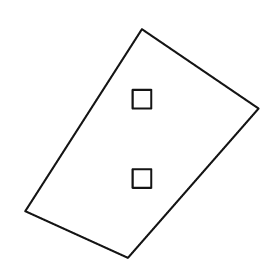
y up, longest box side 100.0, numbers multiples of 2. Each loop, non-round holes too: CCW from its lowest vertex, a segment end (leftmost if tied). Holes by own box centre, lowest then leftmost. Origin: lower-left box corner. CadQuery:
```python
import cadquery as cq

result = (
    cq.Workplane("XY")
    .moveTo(44.0, 0.0)
    .lineTo(100.0, 64.0)
    .lineTo(50.0, 98.0)
    .lineTo(0.0, 20.0)
    .close()
    .moveTo(46.0, 30.0)
    .lineTo(54.0, 30.0)
    .lineTo(54.0, 38.0)
    .lineTo(46.0, 38.0)
    .close()
    .moveTo(46.0, 64.0)
    .lineTo(54.0, 64.0)
    .lineTo(54.0, 72.0)
    .lineTo(46.0, 72.0)
    .close()
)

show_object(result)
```